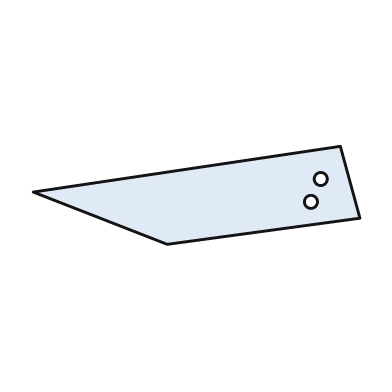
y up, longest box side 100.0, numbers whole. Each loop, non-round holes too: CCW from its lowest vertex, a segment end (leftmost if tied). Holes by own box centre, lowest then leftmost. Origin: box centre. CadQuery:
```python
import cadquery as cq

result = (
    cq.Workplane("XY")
    .moveTo(-9.0, -15.0)
    .lineTo(50.0, -7.0)
    .lineTo(44.0, 15.0)
    .lineTo(-50.0, 1.0)
    .close()
    .moveTo(35.0, -2.0)
    .circle(2.0)
    .moveTo(38.0, 5.0)
    .circle(2.0)
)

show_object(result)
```